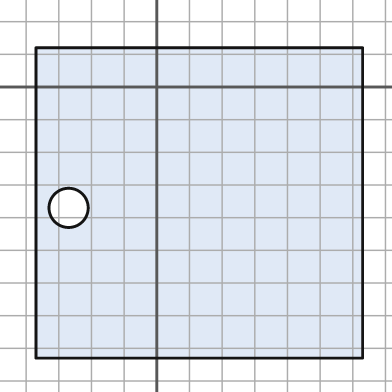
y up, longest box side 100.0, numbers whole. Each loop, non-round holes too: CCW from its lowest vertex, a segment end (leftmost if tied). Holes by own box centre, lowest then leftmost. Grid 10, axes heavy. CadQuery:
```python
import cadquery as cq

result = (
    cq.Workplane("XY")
    .moveTo(-37.0, -83.0)
    .lineTo(63.0, -83.0)
    .lineTo(63.0, 12.0)
    .lineTo(-37.0, 12.0)
    .close()
    .moveTo(-27.0, -37.0)
    .circle(6.0)
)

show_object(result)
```